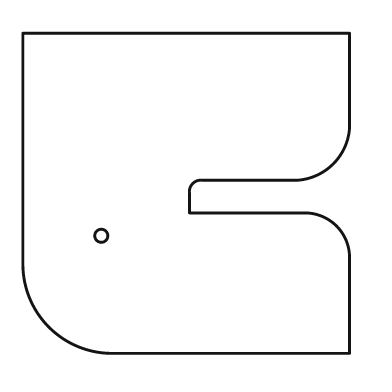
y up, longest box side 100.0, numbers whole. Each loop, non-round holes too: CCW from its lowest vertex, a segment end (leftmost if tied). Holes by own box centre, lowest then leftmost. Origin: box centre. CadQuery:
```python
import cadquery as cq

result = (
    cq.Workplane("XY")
    .moveTo(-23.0, -49.0)
    .lineTo(50.0, -49.0)
    .lineTo(50.0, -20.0)
    .threePointArc((46.0, -10.0), (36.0, -6.0))
    .lineTo(1.0, -6.0)
    .lineTo(1.0, 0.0)
    .threePointArc((2.0, 3.0), (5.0, 4.0))
    .lineTo(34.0, 4.0)
    .threePointArc((45.0, 9.0), (50.0, 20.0))
    .lineTo(50.0, 49.0)
    .lineTo(-50.0, 49.0)
    .lineTo(-50.0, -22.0)
    .threePointArc((-42.0, -41.0), (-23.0, -49.0))
    .close()
    .moveTo(-26.0, -13.0)
    .circle(2.0)
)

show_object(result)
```